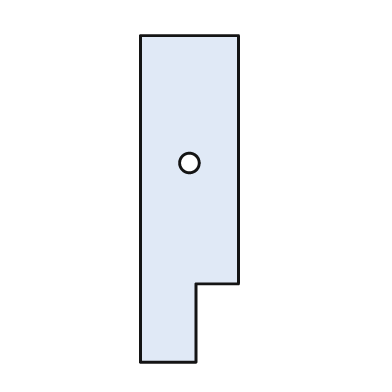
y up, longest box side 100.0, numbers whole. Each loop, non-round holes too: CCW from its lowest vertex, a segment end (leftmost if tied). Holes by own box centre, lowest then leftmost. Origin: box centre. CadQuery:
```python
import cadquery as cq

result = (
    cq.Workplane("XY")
    .moveTo(-15.0, -50.0)
    .lineTo(2.0, -50.0)
    .lineTo(2.0, -26.0)
    .lineTo(15.0, -26.0)
    .lineTo(15.0, 50.0)
    .lineTo(-15.0, 50.0)
    .close()
    .moveTo(0.0, 11.0)
    .circle(3.0)
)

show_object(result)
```